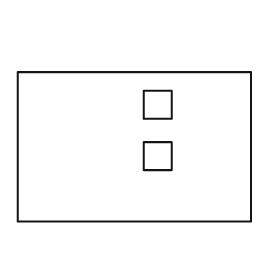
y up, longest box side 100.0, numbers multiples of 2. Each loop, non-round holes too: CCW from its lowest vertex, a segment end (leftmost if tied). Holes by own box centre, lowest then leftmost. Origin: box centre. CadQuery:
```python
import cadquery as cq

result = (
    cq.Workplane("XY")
    .moveTo(-50.0, -32.0)
    .lineTo(50.0, -32.0)
    .lineTo(50.0, 32.0)
    .lineTo(-50.0, 32.0)
    .close()
    .moveTo(4.0, -10.0)
    .lineTo(16.0, -10.0)
    .lineTo(16.0, 2.0)
    .lineTo(4.0, 2.0)
    .close()
    .moveTo(4.0, 12.0)
    .lineTo(16.0, 12.0)
    .lineTo(16.0, 24.0)
    .lineTo(4.0, 24.0)
    .close()
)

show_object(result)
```